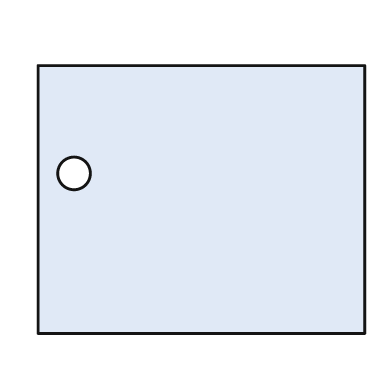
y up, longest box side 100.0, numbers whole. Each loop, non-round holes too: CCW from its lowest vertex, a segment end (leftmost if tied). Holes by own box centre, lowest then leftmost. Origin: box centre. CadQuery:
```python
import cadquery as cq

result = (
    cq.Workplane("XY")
    .moveTo(-50.0, -41.0)
    .lineTo(50.0, -41.0)
    .lineTo(50.0, 41.0)
    .lineTo(-50.0, 41.0)
    .close()
    .moveTo(-39.0, 8.0)
    .circle(5.0)
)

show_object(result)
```